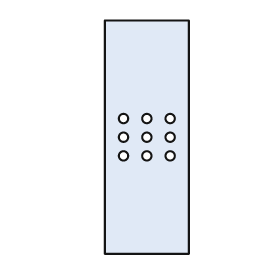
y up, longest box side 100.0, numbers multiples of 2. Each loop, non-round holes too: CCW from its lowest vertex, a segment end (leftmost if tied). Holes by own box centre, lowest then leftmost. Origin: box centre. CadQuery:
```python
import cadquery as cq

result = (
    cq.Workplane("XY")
    .moveTo(-18.0, -50.0)
    .lineTo(18.0, -50.0)
    .lineTo(18.0, 50.0)
    .lineTo(-18.0, 50.0)
    .close()
    .moveTo(-10.0, -8.0)
    .circle(2.0)
    .moveTo(0.0, -8.0)
    .circle(2.0)
    .moveTo(10.0, -8.0)
    .circle(2.0)
    .moveTo(-10.0, 0.0)
    .circle(2.0)
    .moveTo(0.0, 0.0)
    .circle(2.0)
    .moveTo(10.0, 0.0)
    .circle(2.0)
    .moveTo(-10.0, 8.0)
    .circle(2.0)
    .moveTo(0.0, 8.0)
    .circle(2.0)
    .moveTo(10.0, 8.0)
    .circle(2.0)
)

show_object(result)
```